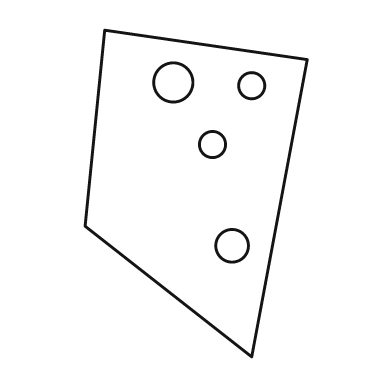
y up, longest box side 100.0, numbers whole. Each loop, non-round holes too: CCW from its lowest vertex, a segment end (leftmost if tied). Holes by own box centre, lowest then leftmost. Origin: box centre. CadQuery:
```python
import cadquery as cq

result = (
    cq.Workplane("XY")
    .moveTo(17.0, -50.0)
    .lineTo(34.0, 41.0)
    .lineTo(-28.0, 50.0)
    .lineTo(-34.0, -10.0)
    .close()
    .moveTo(11.0, -16.0)
    .circle(5.0)
    .moveTo(5.0, 15.0)
    .circle(4.0)
    .moveTo(17.0, 33.0)
    .circle(4.0)
    .moveTo(-7.0, 34.0)
    .circle(6.0)
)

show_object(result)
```